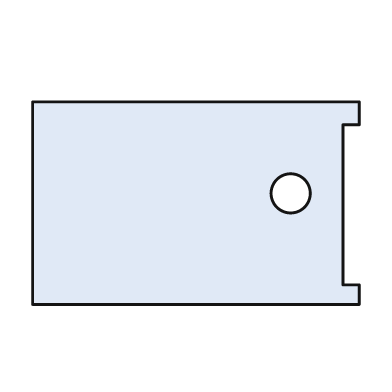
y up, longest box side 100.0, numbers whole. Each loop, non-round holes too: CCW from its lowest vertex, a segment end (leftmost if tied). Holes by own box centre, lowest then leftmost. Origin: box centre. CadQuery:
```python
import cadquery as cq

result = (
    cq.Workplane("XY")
    .moveTo(-50.0, -31.0)
    .lineTo(50.0, -31.0)
    .lineTo(50.0, -25.0)
    .lineTo(45.0, -25.0)
    .lineTo(45.0, 24.0)
    .lineTo(50.0, 24.0)
    .lineTo(50.0, 31.0)
    .lineTo(-50.0, 31.0)
    .close()
    .moveTo(29.0, 3.0)
    .circle(6.0)
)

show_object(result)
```